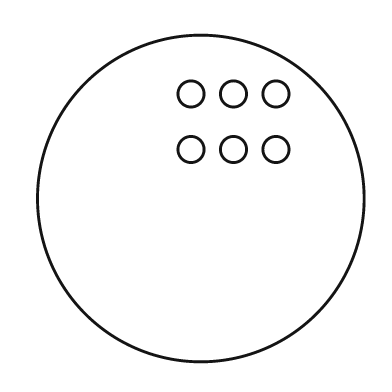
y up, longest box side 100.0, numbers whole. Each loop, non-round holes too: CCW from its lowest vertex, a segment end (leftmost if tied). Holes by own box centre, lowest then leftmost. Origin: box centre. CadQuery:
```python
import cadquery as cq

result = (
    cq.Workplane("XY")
    .moveTo(0.0, 0.0)
    .circle(50.0)
    .moveTo(-3.0, 15.0)
    .circle(4.0)
    .moveTo(10.0, 15.0)
    .circle(4.0)
    .moveTo(23.0, 15.0)
    .circle(4.0)
    .moveTo(-3.0, 32.0)
    .circle(4.0)
    .moveTo(10.0, 32.0)
    .circle(4.0)
    .moveTo(23.0, 32.0)
    .circle(4.0)
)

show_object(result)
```